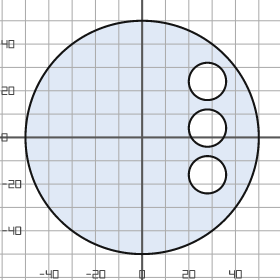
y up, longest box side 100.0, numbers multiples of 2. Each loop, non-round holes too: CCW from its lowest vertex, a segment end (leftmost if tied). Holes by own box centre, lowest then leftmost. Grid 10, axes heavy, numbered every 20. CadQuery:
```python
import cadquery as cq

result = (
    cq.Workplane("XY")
    .moveTo(0.0, 0.0)
    .circle(50.0)
    .moveTo(28.0, -16.0)
    .circle(8.0)
    .moveTo(28.0, 4.0)
    .circle(8.0)
    .moveTo(28.0, 24.0)
    .circle(8.0)
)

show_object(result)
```